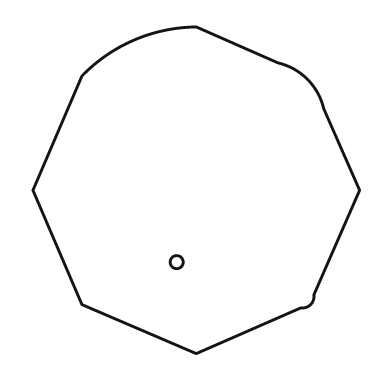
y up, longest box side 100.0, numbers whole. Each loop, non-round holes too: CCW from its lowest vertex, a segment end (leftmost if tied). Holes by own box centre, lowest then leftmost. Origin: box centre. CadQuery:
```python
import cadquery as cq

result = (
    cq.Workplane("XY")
    .moveTo(0.0, -50.0)
    .lineTo(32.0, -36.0)
    .threePointArc((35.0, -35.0), (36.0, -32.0))
    .lineTo(50.0, 0.0)
    .lineTo(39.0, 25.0)
    .threePointArc((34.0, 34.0), (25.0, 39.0))
    .lineTo(0.0, 50.0)
    .threePointArc((-19.0, 46.0), (-35.0, 35.0))
    .lineTo(-50.0, 0.0)
    .lineTo(-35.0, -35.0)
    .close()
    .moveTo(-6.0, -22.0)
    .circle(2.0)
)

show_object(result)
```